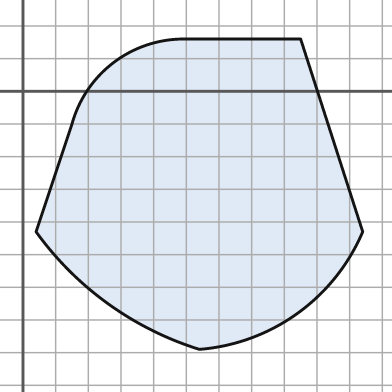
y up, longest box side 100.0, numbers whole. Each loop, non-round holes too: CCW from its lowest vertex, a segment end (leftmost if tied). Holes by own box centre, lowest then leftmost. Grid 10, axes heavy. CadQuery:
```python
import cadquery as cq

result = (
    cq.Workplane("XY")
    .moveTo(54.0, -79.0)
    .threePointArc((84.0, -68.0), (104.0, -43.0))
    .lineTo(85.0, 16.0)
    .lineTo(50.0, 16.0)
    .threePointArc((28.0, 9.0), (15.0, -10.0))
    .lineTo(4.0, -43.0)
    .threePointArc((26.0, -65.0), (54.0, -79.0))
    .close()
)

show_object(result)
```